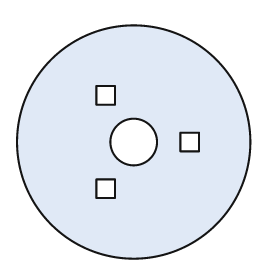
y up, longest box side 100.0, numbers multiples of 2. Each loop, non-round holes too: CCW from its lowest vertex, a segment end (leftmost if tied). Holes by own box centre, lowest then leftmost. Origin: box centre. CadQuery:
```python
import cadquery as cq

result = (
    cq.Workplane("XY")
    .moveTo(0.0, 0.0)
    .circle(50.0)
    .moveTo(-16.0, -24.0)
    .lineTo(-8.0, -24.0)
    .lineTo(-8.0, -16.0)
    .lineTo(-16.0, -16.0)
    .close()
    .moveTo(0.0, 0.0)
    .circle(10.0)
    .moveTo(20.0, -4.0)
    .lineTo(28.0, -4.0)
    .lineTo(28.0, 4.0)
    .lineTo(20.0, 4.0)
    .close()
    .moveTo(-16.0, 16.0)
    .lineTo(-8.0, 16.0)
    .lineTo(-8.0, 24.0)
    .lineTo(-16.0, 24.0)
    .close()
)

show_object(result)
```